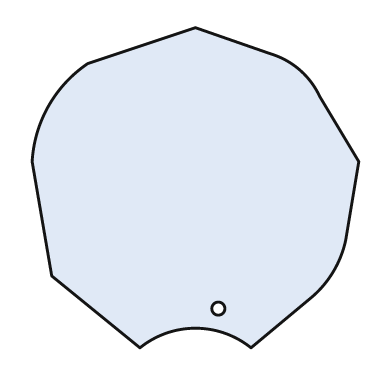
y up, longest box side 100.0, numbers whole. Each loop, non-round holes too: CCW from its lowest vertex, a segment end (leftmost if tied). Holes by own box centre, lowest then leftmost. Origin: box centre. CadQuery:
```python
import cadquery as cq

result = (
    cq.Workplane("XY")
    .moveTo(-17.0, -49.0)
    .threePointArc((0.0, -43.0), (17.0, -49.0))
    .lineTo(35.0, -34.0)
    .threePointArc((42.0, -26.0), (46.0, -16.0))
    .lineTo(50.0, 8.0)
    .lineTo(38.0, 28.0)
    .threePointArc((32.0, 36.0), (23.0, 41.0))
    .lineTo(0.0, 49.0)
    .lineTo(-33.0, 38.0)
    .threePointArc((-45.0, 25.0), (-50.0, 8.0))
    .lineTo(-44.0, -27.0)
    .close()
    .moveTo(7.0, -37.0)
    .circle(2.0)
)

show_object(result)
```